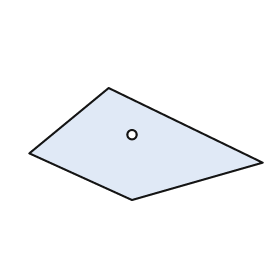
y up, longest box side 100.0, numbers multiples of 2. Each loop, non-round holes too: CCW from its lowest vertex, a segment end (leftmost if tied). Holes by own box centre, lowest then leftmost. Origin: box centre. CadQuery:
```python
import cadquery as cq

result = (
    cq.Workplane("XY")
    .moveTo(-6.0, -24.0)
    .lineTo(50.0, -8.0)
    .lineTo(-16.0, 24.0)
    .lineTo(-50.0, -4.0)
    .close()
    .moveTo(-6.0, 4.0)
    .circle(2.0)
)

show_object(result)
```